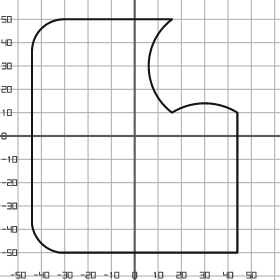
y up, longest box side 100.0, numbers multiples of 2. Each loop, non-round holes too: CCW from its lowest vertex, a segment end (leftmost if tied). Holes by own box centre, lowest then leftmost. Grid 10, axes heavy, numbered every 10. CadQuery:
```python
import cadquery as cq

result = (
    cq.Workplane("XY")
    .moveTo(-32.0, -50.0)
    .lineTo(44.0, -50.0)
    .lineTo(44.0, 10.0)
    .threePointArc((30.0, 14.0), (16.0, 10.0))
    .threePointArc((6.0, 30.0), (16.0, 50.0))
    .lineTo(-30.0, 50.0)
    .threePointArc((-40.0, 46.0), (-44.0, 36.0))
    .lineTo(-44.0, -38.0)
    .threePointArc((-40.0, -46.0), (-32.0, -50.0))
    .close()
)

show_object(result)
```